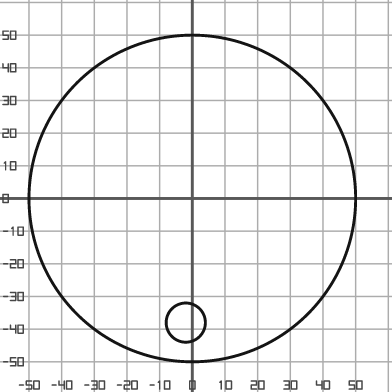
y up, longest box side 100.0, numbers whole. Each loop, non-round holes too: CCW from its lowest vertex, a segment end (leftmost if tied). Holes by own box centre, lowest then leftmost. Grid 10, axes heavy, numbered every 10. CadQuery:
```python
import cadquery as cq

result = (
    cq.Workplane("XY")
    .moveTo(0.0, 0.0)
    .circle(50.0)
    .moveTo(-2.0, -38.0)
    .circle(6.0)
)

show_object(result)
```